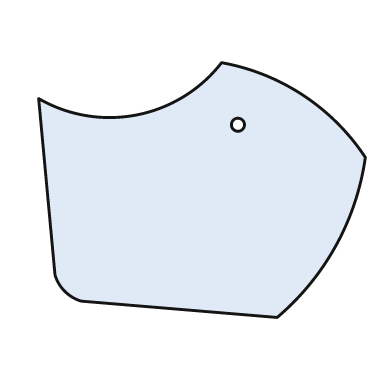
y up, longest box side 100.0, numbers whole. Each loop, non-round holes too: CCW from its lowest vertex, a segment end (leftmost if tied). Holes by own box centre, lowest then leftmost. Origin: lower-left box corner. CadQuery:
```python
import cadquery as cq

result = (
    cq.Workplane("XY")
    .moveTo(73.0, 0.0)
    .threePointArc((91.0, 22.0), (100.0, 49.0))
    .threePointArc((81.0, 68.0), (56.0, 78.0))
    .threePointArc((30.0, 62.0), (0.0, 67.0))
    .lineTo(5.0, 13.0)
    .threePointArc((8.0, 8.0), (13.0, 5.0))
    .close()
    .moveTo(61.0, 59.0)
    .circle(2.0)
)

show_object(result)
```